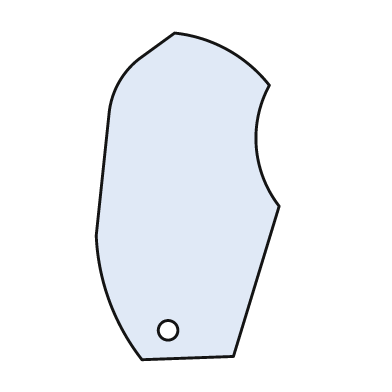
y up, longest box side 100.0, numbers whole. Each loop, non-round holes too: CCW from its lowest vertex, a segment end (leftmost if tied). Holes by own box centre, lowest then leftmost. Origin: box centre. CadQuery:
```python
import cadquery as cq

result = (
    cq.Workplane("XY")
    .moveTo(-14.0, -50.0)
    .lineTo(14.0, -49.0)
    .lineTo(28.0, -3.0)
    .threePointArc((21.0, 15.0), (25.0, 34.0))
    .threePointArc((12.0, 45.0), (-4.0, 50.0))
    .lineTo(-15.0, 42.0)
    .threePointArc((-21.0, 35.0), (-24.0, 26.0))
    .lineTo(-28.0, -12.0)
    .threePointArc((-24.0, -32.0), (-14.0, -50.0))
    .close()
    .moveTo(-6.0, -41.0)
    .circle(3.0)
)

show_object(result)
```